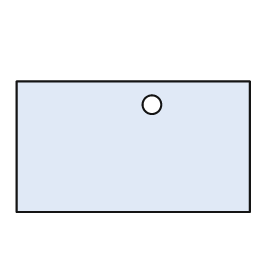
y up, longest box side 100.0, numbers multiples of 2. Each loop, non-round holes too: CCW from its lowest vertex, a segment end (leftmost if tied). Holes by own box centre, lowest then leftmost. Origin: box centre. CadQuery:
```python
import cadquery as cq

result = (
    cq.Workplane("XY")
    .moveTo(-50.0, -28.0)
    .lineTo(50.0, -28.0)
    .lineTo(50.0, 28.0)
    .lineTo(-50.0, 28.0)
    .close()
    .moveTo(8.0, 18.0)
    .circle(4.0)
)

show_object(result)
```